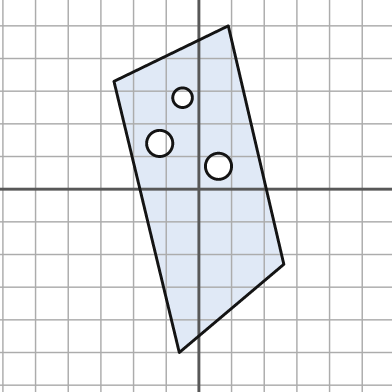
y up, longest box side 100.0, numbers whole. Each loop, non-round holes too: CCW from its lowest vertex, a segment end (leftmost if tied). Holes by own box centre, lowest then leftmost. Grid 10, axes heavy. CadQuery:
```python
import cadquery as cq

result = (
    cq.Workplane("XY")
    .moveTo(-6.0, -50.0)
    .lineTo(26.0, -23.0)
    .lineTo(9.0, 50.0)
    .lineTo(-26.0, 33.0)
    .close()
    .moveTo(6.0, 7.0)
    .circle(4.0)
    .moveTo(-12.0, 14.0)
    .circle(4.0)
    .moveTo(-5.0, 28.0)
    .circle(3.0)
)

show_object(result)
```